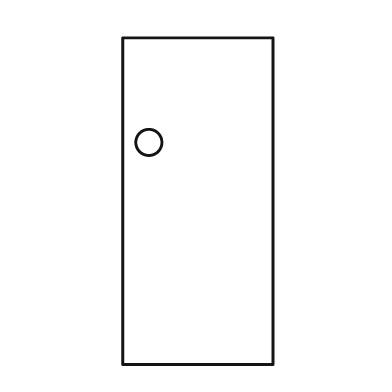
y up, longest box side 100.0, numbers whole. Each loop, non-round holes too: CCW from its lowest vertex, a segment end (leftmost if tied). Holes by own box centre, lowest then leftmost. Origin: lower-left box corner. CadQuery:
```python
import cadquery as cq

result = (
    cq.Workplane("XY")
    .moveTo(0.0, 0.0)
    .lineTo(46.0, 0.0)
    .lineTo(46.0, 100.0)
    .lineTo(0.0, 100.0)
    .close()
    .moveTo(8.0, 68.0)
    .circle(4.0)
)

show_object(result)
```